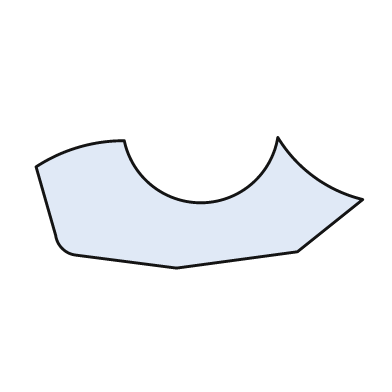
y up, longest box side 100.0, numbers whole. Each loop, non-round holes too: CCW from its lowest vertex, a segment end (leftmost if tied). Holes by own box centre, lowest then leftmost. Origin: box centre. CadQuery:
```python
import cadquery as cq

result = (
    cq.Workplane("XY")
    .moveTo(-7.0, -20.0)
    .lineTo(30.0, -15.0)
    .lineTo(50.0, 1.0)
    .threePointArc((35.0, 8.0), (24.0, 20.0))
    .threePointArc((1.0, 0.0), (-23.0, 19.0))
    .threePointArc((-37.0, 17.0), (-50.0, 11.0))
    .lineTo(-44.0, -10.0)
    .threePointArc((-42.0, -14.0), (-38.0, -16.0))
    .close()
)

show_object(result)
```